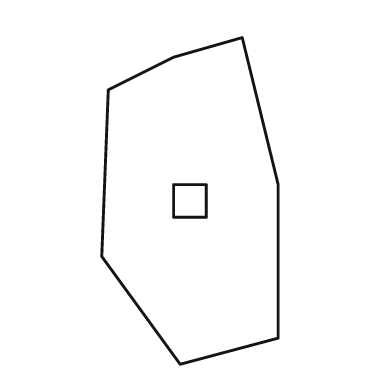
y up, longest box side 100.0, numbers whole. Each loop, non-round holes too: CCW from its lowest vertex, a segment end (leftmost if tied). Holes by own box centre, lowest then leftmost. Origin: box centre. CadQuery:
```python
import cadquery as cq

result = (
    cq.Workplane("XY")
    .moveTo(-3.0, -50.0)
    .lineTo(27.0, -42.0)
    .lineTo(27.0, 5.0)
    .lineTo(16.0, 50.0)
    .lineTo(-5.0, 44.0)
    .lineTo(-25.0, 34.0)
    .lineTo(-27.0, -17.0)
    .close()
    .moveTo(-5.0, -5.0)
    .lineTo(5.0, -5.0)
    .lineTo(5.0, 5.0)
    .lineTo(-5.0, 5.0)
    .close()
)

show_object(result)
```